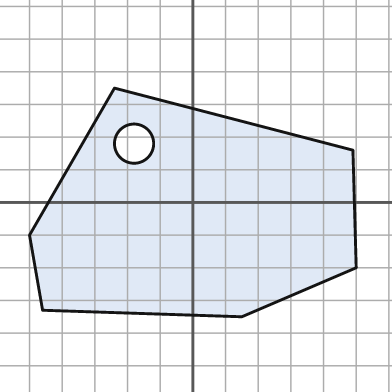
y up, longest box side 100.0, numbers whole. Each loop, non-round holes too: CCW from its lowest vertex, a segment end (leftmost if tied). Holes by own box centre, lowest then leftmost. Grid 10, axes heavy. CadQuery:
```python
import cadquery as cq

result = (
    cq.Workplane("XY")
    .moveTo(15.0, -35.0)
    .lineTo(50.0, -20.0)
    .lineTo(49.0, 16.0)
    .lineTo(-24.0, 35.0)
    .lineTo(-50.0, -10.0)
    .lineTo(-46.0, -33.0)
    .close()
    .moveTo(-18.0, 18.0)
    .circle(6.0)
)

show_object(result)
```